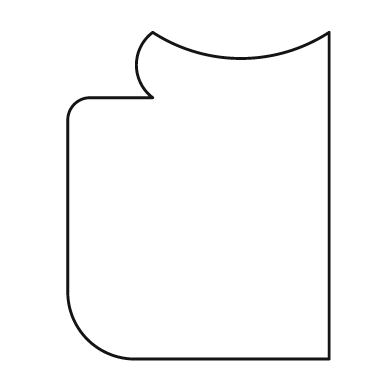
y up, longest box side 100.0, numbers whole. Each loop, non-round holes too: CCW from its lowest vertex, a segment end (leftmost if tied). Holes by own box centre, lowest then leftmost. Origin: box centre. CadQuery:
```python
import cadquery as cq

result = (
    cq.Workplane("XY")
    .moveTo(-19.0, -50.0)
    .lineTo(40.0, -50.0)
    .lineTo(40.0, 50.0)
    .threePointArc((13.0, 42.0), (-14.0, 50.0))
    .threePointArc((-19.0, 40.0), (-14.0, 30.0))
    .lineTo(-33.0, 30.0)
    .threePointArc((-38.0, 28.0), (-40.0, 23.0))
    .lineTo(-40.0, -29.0)
    .threePointArc((-34.0, -44.0), (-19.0, -50.0))
    .close()
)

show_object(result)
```